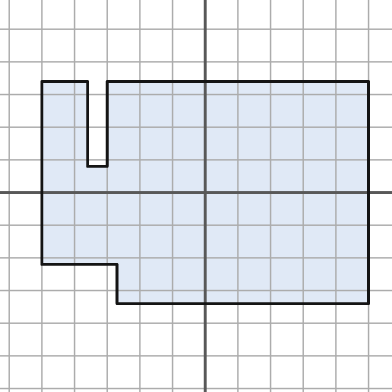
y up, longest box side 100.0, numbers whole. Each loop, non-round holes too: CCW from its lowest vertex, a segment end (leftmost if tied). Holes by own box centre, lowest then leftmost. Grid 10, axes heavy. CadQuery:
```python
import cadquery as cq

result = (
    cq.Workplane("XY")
    .moveTo(-27.0, -34.0)
    .lineTo(50.0, -34.0)
    .lineTo(50.0, 34.0)
    .lineTo(-30.0, 34.0)
    .lineTo(-30.0, 8.0)
    .lineTo(-36.0, 8.0)
    .lineTo(-36.0, 34.0)
    .lineTo(-50.0, 34.0)
    .lineTo(-50.0, -22.0)
    .lineTo(-27.0, -22.0)
    .close()
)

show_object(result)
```